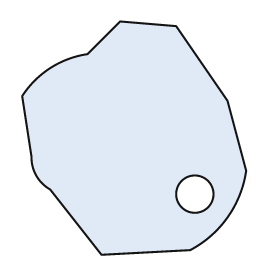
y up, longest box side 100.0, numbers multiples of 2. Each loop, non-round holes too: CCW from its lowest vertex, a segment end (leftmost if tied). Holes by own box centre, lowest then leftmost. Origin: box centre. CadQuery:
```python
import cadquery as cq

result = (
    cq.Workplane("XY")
    .moveTo(-14.0, -50.0)
    .lineTo(24.0, -48.0)
    .threePointArc((40.0, -34.0), (48.0, -14.0))
    .lineTo(40.0, 16.0)
    .lineTo(18.0, 48.0)
    .lineTo(-6.0, 50.0)
    .lineTo(-20.0, 36.0)
    .threePointArc((-36.0, 30.0), (-48.0, 18.0))
    .lineTo(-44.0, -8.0)
    .threePointArc((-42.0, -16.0), (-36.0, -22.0))
    .close()
    .moveTo(26.0, -24.0)
    .circle(8.0)
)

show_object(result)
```